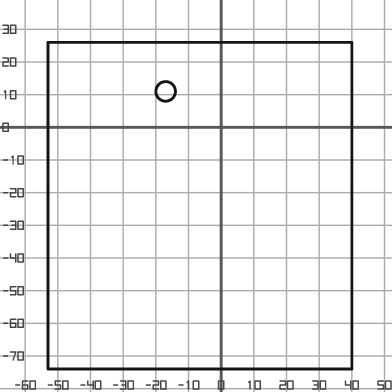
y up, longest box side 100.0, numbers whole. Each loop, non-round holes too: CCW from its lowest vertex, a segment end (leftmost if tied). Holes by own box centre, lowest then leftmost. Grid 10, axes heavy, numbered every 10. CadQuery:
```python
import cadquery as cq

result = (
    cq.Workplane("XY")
    .moveTo(-53.0, -74.0)
    .lineTo(40.0, -74.0)
    .lineTo(40.0, 26.0)
    .lineTo(-53.0, 26.0)
    .close()
    .moveTo(-17.0, 11.0)
    .circle(3.0)
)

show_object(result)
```